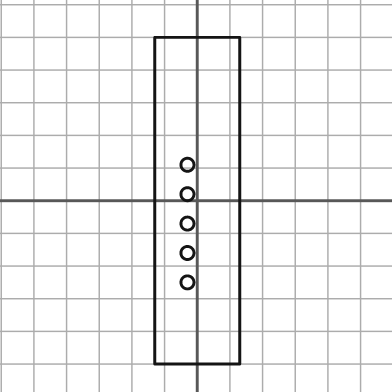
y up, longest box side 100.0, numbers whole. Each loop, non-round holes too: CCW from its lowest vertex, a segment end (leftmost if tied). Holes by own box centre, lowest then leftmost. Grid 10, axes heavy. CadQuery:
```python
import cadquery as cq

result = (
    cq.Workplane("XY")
    .moveTo(-13.0, -50.0)
    .lineTo(13.0, -50.0)
    .lineTo(13.0, 50.0)
    .lineTo(-13.0, 50.0)
    .close()
    .moveTo(-3.0, -25.0)
    .circle(2.0)
    .moveTo(-3.0, -16.0)
    .circle(2.0)
    .moveTo(-3.0, -7.0)
    .circle(2.0)
    .moveTo(-3.0, 2.0)
    .circle(2.0)
    .moveTo(-3.0, 11.0)
    .circle(2.0)
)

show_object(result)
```